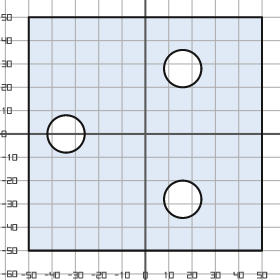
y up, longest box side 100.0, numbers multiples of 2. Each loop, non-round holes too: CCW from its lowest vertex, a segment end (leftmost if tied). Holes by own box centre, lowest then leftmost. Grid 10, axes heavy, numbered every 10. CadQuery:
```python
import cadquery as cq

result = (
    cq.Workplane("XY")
    .moveTo(-50.0, -50.0)
    .lineTo(50.0, -50.0)
    .lineTo(50.0, 50.0)
    .lineTo(-50.0, 50.0)
    .close()
    .moveTo(16.0, -28.0)
    .circle(8.0)
    .moveTo(-34.0, 0.0)
    .circle(8.0)
    .moveTo(16.0, 28.0)
    .circle(8.0)
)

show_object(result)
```